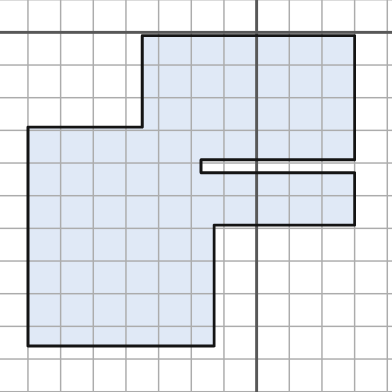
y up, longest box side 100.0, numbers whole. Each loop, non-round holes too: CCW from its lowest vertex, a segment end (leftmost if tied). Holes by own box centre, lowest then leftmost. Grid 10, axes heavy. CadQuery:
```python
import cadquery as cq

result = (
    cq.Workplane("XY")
    .moveTo(-70.0, -96.0)
    .lineTo(-13.0, -96.0)
    .lineTo(-13.0, -59.0)
    .lineTo(30.0, -59.0)
    .lineTo(30.0, -43.0)
    .lineTo(-17.0, -43.0)
    .lineTo(-17.0, -39.0)
    .lineTo(30.0, -39.0)
    .lineTo(30.0, -1.0)
    .lineTo(-35.0, -1.0)
    .lineTo(-35.0, -29.0)
    .lineTo(-70.0, -29.0)
    .close()
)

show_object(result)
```